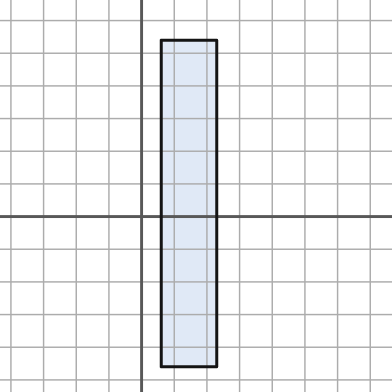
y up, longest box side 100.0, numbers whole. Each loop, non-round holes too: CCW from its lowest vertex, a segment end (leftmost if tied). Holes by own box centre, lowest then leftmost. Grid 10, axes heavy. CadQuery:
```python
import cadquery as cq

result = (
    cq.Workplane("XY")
    .moveTo(6.0, -46.0)
    .lineTo(23.0, -46.0)
    .lineTo(23.0, 54.0)
    .lineTo(6.0, 54.0)
    .close()
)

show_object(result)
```